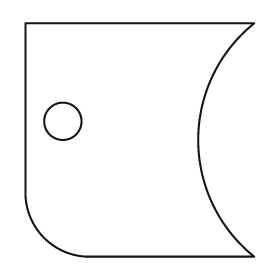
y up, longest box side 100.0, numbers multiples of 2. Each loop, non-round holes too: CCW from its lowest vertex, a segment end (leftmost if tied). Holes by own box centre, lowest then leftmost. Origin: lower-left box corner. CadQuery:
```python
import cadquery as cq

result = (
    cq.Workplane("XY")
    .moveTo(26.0, 0.0)
    .lineTo(98.0, 0.0)
    .threePointArc((74.0, 50.0), (98.0, 100.0))
    .lineTo(0.0, 100.0)
    .lineTo(0.0, 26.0)
    .threePointArc((8.0, 8.0), (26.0, 0.0))
    .close()
    .moveTo(16.0, 58.0)
    .circle(8.0)
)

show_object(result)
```